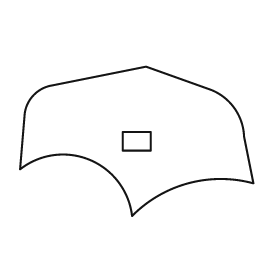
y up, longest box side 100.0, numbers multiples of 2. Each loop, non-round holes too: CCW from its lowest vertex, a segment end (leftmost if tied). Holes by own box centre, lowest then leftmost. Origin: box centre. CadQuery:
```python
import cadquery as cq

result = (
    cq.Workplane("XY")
    .moveTo(-2.0, -32.0)
    .threePointArc((22.0, -18.0), (50.0, -18.0))
    .lineTo(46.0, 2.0)
    .threePointArc((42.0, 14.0), (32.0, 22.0))
    .lineTo(4.0, 32.0)
    .lineTo(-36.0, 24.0)
    .threePointArc((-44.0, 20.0), (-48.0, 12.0))
    .lineTo(-50.0, -12.0)
    .threePointArc((-20.0, -8.0), (-2.0, -32.0))
    .close()
    .moveTo(-6.0, -4.0)
    .lineTo(6.0, -4.0)
    .lineTo(6.0, 4.0)
    .lineTo(-6.0, 4.0)
    .close()
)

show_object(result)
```